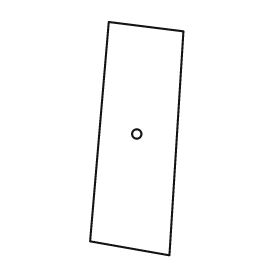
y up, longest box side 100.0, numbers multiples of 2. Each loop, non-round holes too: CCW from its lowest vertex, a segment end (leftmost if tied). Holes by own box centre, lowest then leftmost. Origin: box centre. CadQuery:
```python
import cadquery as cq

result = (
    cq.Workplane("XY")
    .moveTo(14.0, -50.0)
    .lineTo(20.0, 46.0)
    .lineTo(-12.0, 50.0)
    .lineTo(-20.0, -44.0)
    .close()
    .moveTo(0.0, 2.0)
    .circle(2.0)
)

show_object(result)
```